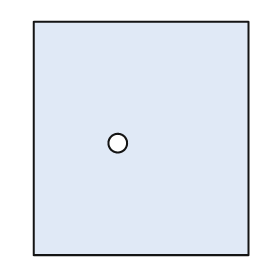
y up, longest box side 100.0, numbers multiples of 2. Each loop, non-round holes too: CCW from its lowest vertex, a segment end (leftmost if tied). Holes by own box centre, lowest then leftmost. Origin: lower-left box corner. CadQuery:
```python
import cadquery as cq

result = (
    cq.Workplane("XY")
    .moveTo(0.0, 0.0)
    .lineTo(92.0, 0.0)
    .lineTo(92.0, 100.0)
    .lineTo(0.0, 100.0)
    .close()
    .moveTo(36.0, 48.0)
    .circle(4.0)
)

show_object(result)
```